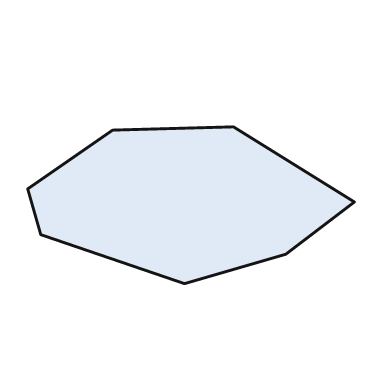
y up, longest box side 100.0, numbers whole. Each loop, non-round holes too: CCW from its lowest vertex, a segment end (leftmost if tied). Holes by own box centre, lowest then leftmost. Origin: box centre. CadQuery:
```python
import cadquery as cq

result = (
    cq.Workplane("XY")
    .moveTo(-2.0, -24.0)
    .lineTo(29.0, -15.0)
    .lineTo(50.0, 1.0)
    .lineTo(13.0, 24.0)
    .lineTo(-24.0, 23.0)
    .lineTo(-50.0, 5.0)
    .lineTo(-46.0, -9.0)
    .close()
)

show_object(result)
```